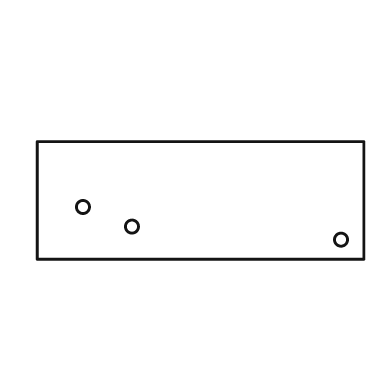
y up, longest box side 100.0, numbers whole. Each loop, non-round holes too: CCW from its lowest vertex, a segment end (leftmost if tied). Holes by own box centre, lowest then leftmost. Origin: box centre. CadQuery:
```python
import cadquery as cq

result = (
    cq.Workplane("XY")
    .moveTo(-50.0, -18.0)
    .lineTo(50.0, -18.0)
    .lineTo(50.0, 18.0)
    .lineTo(-50.0, 18.0)
    .close()
    .moveTo(43.0, -12.0)
    .circle(2.0)
    .moveTo(-21.0, -8.0)
    .circle(2.0)
    .moveTo(-36.0, -2.0)
    .circle(2.0)
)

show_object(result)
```